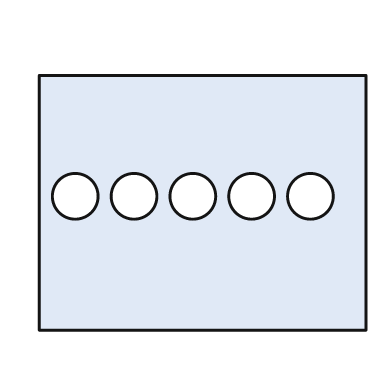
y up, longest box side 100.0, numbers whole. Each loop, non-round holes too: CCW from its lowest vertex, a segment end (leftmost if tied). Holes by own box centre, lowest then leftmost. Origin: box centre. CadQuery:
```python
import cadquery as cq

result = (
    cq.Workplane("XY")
    .moveTo(-50.0, -39.0)
    .lineTo(50.0, -39.0)
    .lineTo(50.0, 39.0)
    .lineTo(-50.0, 39.0)
    .close()
    .moveTo(-39.0, 2.0)
    .circle(7.0)
    .moveTo(-21.0, 2.0)
    .circle(7.0)
    .moveTo(-3.0, 2.0)
    .circle(7.0)
    .moveTo(15.0, 2.0)
    .circle(7.0)
    .moveTo(33.0, 2.0)
    .circle(7.0)
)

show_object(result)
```